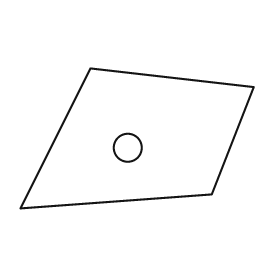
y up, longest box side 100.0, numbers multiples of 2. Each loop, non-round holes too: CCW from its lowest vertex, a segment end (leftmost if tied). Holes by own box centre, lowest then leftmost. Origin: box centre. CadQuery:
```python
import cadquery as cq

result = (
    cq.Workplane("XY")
    .moveTo(-50.0, -30.0)
    .lineTo(32.0, -24.0)
    .lineTo(50.0, 22.0)
    .lineTo(-20.0, 30.0)
    .close()
    .moveTo(-4.0, -4.0)
    .circle(6.0)
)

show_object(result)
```